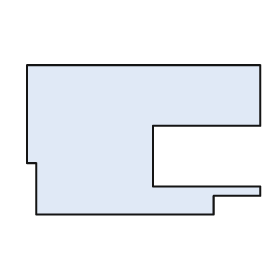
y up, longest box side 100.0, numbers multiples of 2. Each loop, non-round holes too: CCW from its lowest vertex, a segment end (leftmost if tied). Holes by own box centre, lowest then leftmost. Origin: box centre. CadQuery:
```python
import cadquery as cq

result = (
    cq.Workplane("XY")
    .moveTo(-46.0, -32.0)
    .lineTo(30.0, -32.0)
    .lineTo(30.0, -24.0)
    .lineTo(50.0, -24.0)
    .lineTo(50.0, -20.0)
    .lineTo(4.0, -20.0)
    .lineTo(4.0, 6.0)
    .lineTo(50.0, 6.0)
    .lineTo(50.0, 32.0)
    .lineTo(-50.0, 32.0)
    .lineTo(-50.0, -10.0)
    .lineTo(-46.0, -10.0)
    .close()
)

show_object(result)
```